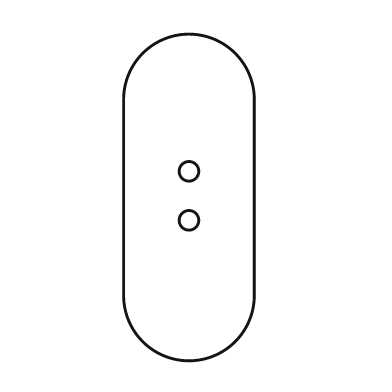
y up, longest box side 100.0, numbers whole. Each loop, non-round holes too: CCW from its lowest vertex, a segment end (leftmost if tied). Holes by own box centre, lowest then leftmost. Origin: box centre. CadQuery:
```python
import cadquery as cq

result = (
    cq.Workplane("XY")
    .moveTo(-20.0, -30.0)
    .threePointArc((0.0, -50.0), (20.0, -30.0))
    .lineTo(20.0, 30.0)
    .threePointArc((0.0, 50.0), (-20.0, 30.0))
    .close()
    .moveTo(0.0, -7.0)
    .circle(3.0)
    .moveTo(0.0, 8.0)
    .circle(3.0)
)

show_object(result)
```